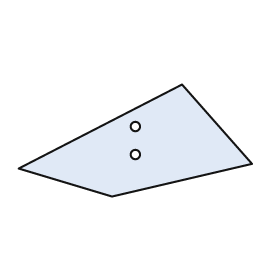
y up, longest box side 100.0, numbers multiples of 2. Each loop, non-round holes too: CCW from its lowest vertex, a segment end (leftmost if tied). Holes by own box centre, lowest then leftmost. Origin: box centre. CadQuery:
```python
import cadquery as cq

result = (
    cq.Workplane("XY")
    .moveTo(-10.0, -24.0)
    .lineTo(50.0, -10.0)
    .lineTo(20.0, 24.0)
    .lineTo(-50.0, -12.0)
    .close()
    .moveTo(0.0, -6.0)
    .circle(2.0)
    .moveTo(0.0, 6.0)
    .circle(2.0)
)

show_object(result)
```